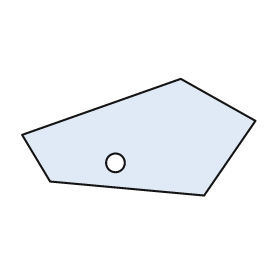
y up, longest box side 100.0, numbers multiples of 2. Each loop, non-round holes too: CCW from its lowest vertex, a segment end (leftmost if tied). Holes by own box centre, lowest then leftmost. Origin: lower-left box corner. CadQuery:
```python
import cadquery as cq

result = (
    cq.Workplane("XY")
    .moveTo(78.0, 0.0)
    .lineTo(100.0, 32.0)
    .lineTo(68.0, 50.0)
    .lineTo(0.0, 26.0)
    .lineTo(12.0, 6.0)
    .close()
    .moveTo(40.0, 14.0)
    .circle(4.0)
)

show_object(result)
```